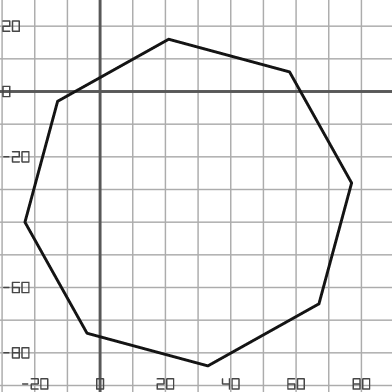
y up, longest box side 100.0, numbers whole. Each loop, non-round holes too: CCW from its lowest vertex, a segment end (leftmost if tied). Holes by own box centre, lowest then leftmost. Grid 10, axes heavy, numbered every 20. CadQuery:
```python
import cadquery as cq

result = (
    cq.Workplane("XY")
    .moveTo(33.0, -84.0)
    .lineTo(67.0, -65.0)
    .lineTo(77.0, -28.0)
    .lineTo(58.0, 6.0)
    .lineTo(21.0, 16.0)
    .lineTo(-13.0, -3.0)
    .lineTo(-23.0, -40.0)
    .lineTo(-4.0, -74.0)
    .close()
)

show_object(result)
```